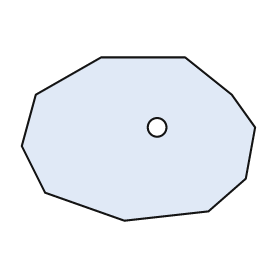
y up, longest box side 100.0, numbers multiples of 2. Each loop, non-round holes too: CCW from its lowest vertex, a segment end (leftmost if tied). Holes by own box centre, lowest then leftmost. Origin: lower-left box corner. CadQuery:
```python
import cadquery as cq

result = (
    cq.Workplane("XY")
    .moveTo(44.0, 0.0)
    .lineTo(80.0, 4.0)
    .lineTo(96.0, 18.0)
    .lineTo(100.0, 40.0)
    .lineTo(90.0, 54.0)
    .lineTo(70.0, 70.0)
    .lineTo(34.0, 70.0)
    .lineTo(6.0, 54.0)
    .lineTo(0.0, 32.0)
    .lineTo(10.0, 12.0)
    .close()
    .moveTo(58.0, 40.0)
    .circle(4.0)
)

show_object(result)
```